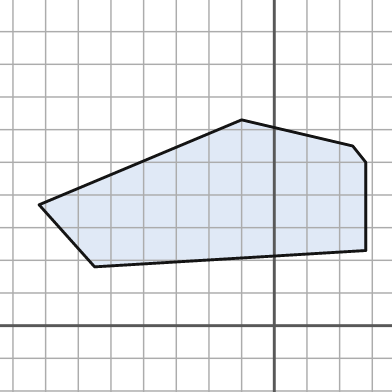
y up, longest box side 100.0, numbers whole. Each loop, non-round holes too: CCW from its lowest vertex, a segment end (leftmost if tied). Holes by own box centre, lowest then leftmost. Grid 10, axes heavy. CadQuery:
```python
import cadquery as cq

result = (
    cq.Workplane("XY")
    .moveTo(-55.0, 18.0)
    .lineTo(28.0, 23.0)
    .lineTo(28.0, 50.0)
    .lineTo(24.0, 55.0)
    .lineTo(-10.0, 63.0)
    .lineTo(-72.0, 37.0)
    .close()
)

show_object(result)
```